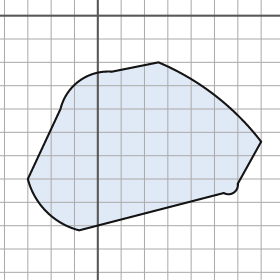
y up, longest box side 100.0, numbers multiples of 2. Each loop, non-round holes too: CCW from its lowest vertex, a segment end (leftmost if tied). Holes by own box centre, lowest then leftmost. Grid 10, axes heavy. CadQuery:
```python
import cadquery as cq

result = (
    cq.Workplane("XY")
    .moveTo(-8.0, -92.0)
    .lineTo(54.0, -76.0)
    .threePointArc((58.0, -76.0), (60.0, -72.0))
    .lineTo(70.0, -54.0)
    .threePointArc((50.0, -34.0), (26.0, -20.0))
    .lineTo(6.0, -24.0)
    .threePointArc((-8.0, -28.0), (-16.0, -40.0))
    .lineTo(-30.0, -70.0)
    .threePointArc((-22.0, -84.0), (-8.0, -92.0))
    .close()
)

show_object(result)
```